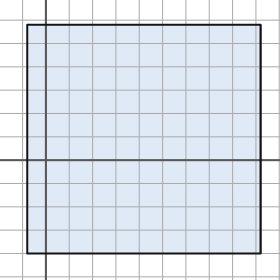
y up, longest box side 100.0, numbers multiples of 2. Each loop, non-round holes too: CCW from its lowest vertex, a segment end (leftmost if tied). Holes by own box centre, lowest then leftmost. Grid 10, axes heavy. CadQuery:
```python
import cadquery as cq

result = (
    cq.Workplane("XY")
    .moveTo(-8.0, -40.0)
    .lineTo(92.0, -40.0)
    .lineTo(92.0, 58.0)
    .lineTo(-8.0, 58.0)
    .close()
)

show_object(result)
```